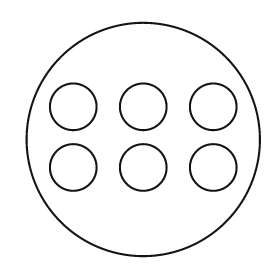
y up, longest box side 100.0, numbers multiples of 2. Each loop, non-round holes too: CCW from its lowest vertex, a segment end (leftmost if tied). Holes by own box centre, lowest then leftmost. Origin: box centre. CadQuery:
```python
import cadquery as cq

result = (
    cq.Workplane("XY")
    .moveTo(0.0, 0.0)
    .circle(50.0)
    .moveTo(-30.0, -12.0)
    .circle(10.0)
    .moveTo(0.0, -12.0)
    .circle(10.0)
    .moveTo(30.0, -12.0)
    .circle(10.0)
    .moveTo(-30.0, 14.0)
    .circle(10.0)
    .moveTo(0.0, 14.0)
    .circle(10.0)
    .moveTo(30.0, 14.0)
    .circle(10.0)
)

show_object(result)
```